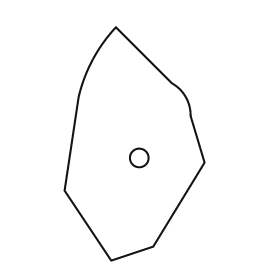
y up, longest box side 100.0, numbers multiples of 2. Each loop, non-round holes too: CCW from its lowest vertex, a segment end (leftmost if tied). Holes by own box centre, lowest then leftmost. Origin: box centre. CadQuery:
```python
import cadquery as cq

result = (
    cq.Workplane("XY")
    .moveTo(-10.0, -50.0)
    .lineTo(8.0, -44.0)
    .lineTo(30.0, -8.0)
    .lineTo(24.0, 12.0)
    .threePointArc((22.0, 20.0), (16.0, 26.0))
    .lineTo(-8.0, 50.0)
    .threePointArc((-18.0, 36.0), (-24.0, 20.0))
    .lineTo(-30.0, -20.0)
    .close()
    .moveTo(2.0, -6.0)
    .circle(4.0)
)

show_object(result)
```